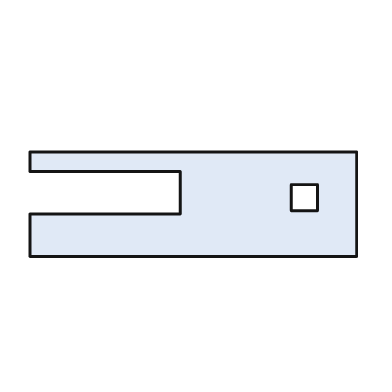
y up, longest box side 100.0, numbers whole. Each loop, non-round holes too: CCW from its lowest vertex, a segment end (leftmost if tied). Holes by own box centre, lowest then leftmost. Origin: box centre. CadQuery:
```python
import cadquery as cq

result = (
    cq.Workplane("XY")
    .moveTo(-50.0, -16.0)
    .lineTo(50.0, -16.0)
    .lineTo(50.0, 16.0)
    .lineTo(-50.0, 16.0)
    .lineTo(-50.0, 10.0)
    .lineTo(-4.0, 10.0)
    .lineTo(-4.0, -3.0)
    .lineTo(-50.0, -3.0)
    .close()
    .moveTo(30.0, -2.0)
    .lineTo(38.0, -2.0)
    .lineTo(38.0, 6.0)
    .lineTo(30.0, 6.0)
    .close()
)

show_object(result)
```